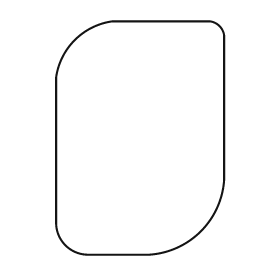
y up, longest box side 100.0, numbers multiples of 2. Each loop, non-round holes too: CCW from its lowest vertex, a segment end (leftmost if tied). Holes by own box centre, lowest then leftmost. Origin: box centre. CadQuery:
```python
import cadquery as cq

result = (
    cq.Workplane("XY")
    .moveTo(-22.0, -50.0)
    .lineTo(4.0, -50.0)
    .threePointArc((26.0, -40.0), (36.0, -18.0))
    .lineTo(36.0, 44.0)
    .threePointArc((34.0, 48.0), (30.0, 50.0))
    .lineTo(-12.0, 50.0)
    .threePointArc((-28.0, 42.0), (-36.0, 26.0))
    .lineTo(-36.0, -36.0)
    .threePointArc((-32.0, -46.0), (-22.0, -50.0))
    .close()
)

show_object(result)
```